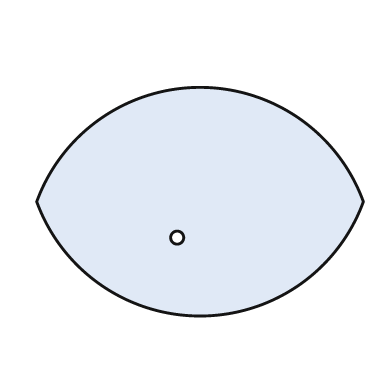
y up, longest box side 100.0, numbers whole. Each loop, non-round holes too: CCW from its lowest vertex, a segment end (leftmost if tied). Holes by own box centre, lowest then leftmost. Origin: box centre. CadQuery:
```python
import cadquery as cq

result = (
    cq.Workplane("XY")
    .moveTo(-50.0, 0.0)
    .threePointArc((0.0, -35.0), (50.0, 0.0))
    .threePointArc((0.0, 35.0), (-50.0, 0.0))
    .close()
    .moveTo(-7.0, -11.0)
    .circle(2.0)
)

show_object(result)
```